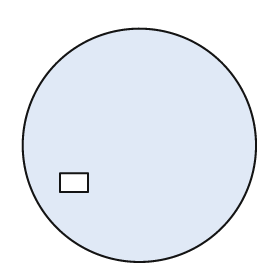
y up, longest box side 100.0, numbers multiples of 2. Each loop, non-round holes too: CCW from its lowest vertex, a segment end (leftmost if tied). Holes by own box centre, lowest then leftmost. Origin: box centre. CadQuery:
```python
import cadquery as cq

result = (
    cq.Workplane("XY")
    .moveTo(0.0, 0.0)
    .circle(50.0)
    .moveTo(-34.0, -20.0)
    .lineTo(-22.0, -20.0)
    .lineTo(-22.0, -12.0)
    .lineTo(-34.0, -12.0)
    .close()
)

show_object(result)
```